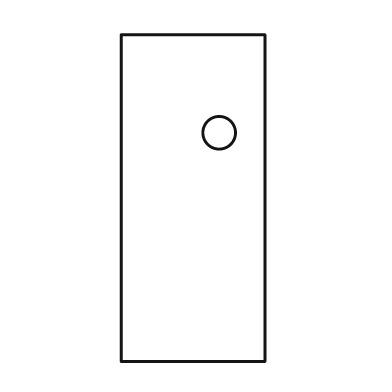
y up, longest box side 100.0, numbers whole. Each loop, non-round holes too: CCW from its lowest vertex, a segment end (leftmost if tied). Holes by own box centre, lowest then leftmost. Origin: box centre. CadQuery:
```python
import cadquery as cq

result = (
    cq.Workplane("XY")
    .moveTo(-22.0, -50.0)
    .lineTo(22.0, -50.0)
    .lineTo(22.0, 50.0)
    .lineTo(-22.0, 50.0)
    .close()
    .moveTo(8.0, 20.0)
    .circle(5.0)
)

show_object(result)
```